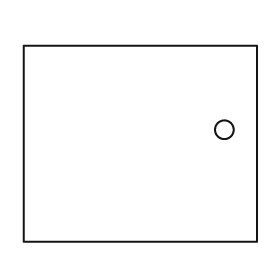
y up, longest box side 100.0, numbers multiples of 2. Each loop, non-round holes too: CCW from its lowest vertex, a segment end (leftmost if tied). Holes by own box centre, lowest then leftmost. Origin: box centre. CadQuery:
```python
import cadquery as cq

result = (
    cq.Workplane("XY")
    .moveTo(-50.0, -42.0)
    .lineTo(50.0, -42.0)
    .lineTo(50.0, 42.0)
    .lineTo(-50.0, 42.0)
    .close()
    .moveTo(36.0, 6.0)
    .circle(4.0)
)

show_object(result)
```